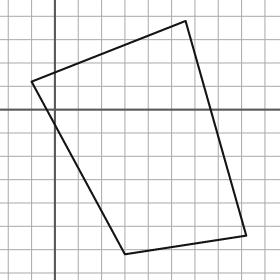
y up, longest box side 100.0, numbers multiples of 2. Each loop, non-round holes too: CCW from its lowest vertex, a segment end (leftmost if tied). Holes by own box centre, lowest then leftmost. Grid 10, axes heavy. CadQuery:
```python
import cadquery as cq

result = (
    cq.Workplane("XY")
    .moveTo(30.0, -62.0)
    .lineTo(82.0, -54.0)
    .lineTo(56.0, 38.0)
    .lineTo(-10.0, 12.0)
    .close()
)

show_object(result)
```